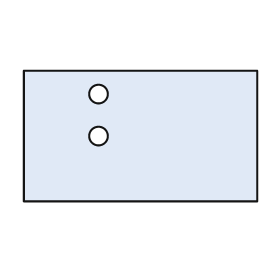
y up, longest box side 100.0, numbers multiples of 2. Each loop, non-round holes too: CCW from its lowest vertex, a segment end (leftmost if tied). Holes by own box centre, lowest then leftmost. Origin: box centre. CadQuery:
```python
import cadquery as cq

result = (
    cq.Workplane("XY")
    .moveTo(-50.0, -28.0)
    .lineTo(50.0, -28.0)
    .lineTo(50.0, 28.0)
    .lineTo(-50.0, 28.0)
    .close()
    .moveTo(-18.0, 0.0)
    .circle(4.0)
    .moveTo(-18.0, 18.0)
    .circle(4.0)
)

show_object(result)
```